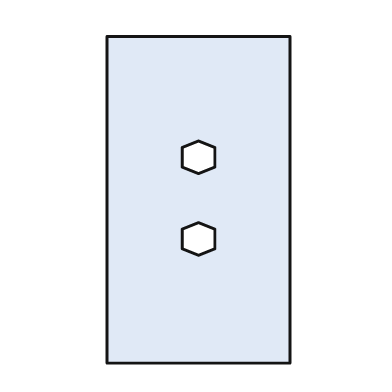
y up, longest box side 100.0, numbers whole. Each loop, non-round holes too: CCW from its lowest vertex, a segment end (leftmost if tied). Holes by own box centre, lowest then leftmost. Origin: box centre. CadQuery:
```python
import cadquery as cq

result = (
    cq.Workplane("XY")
    .moveTo(-28.0, -50.0)
    .lineTo(28.0, -50.0)
    .lineTo(28.0, 50.0)
    .lineTo(-28.0, 50.0)
    .close()
    .moveTo(0.0, -17.0)
    .lineTo(5.0, -15.0)
    .lineTo(5.0, -9.0)
    .lineTo(0.0, -7.0)
    .lineTo(-5.0, -9.0)
    .lineTo(-5.0, -15.0)
    .close()
    .moveTo(0.0, 8.0)
    .lineTo(5.0, 10.0)
    .lineTo(5.0, 16.0)
    .lineTo(0.0, 18.0)
    .lineTo(-5.0, 16.0)
    .lineTo(-5.0, 10.0)
    .close()
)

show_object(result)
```